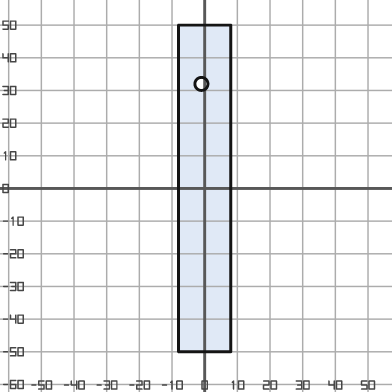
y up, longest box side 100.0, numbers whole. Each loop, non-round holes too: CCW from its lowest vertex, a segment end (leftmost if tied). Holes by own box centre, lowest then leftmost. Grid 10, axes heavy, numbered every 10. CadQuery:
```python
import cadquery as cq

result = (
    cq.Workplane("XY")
    .moveTo(-8.0, -50.0)
    .lineTo(8.0, -50.0)
    .lineTo(8.0, 50.0)
    .lineTo(-8.0, 50.0)
    .close()
    .moveTo(-1.0, 32.0)
    .circle(2.0)
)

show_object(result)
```